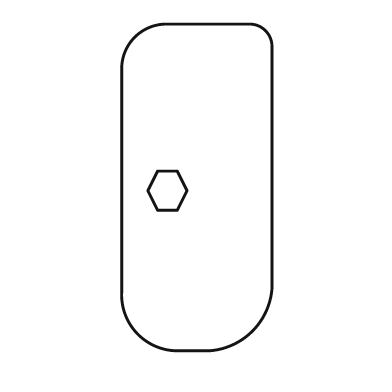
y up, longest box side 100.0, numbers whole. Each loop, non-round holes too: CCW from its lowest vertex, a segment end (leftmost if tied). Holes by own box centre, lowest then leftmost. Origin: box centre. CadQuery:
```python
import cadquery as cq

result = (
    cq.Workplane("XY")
    .moveTo(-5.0, -50.0)
    .lineTo(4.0, -50.0)
    .threePointArc((17.0, -44.0), (23.0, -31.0))
    .lineTo(23.0, 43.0)
    .threePointArc((21.0, 48.0), (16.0, 50.0))
    .lineTo(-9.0, 50.0)
    .threePointArc((-19.0, 46.0), (-23.0, 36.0))
    .lineTo(-23.0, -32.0)
    .threePointArc((-18.0, -45.0), (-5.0, -50.0))
    .close()
    .moveTo(-12.0, -7.0)
    .lineTo(-6.0, -7.0)
    .lineTo(-3.0, -1.0)
    .lineTo(-6.0, 5.0)
    .lineTo(-12.0, 5.0)
    .lineTo(-15.0, -1.0)
    .close()
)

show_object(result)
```